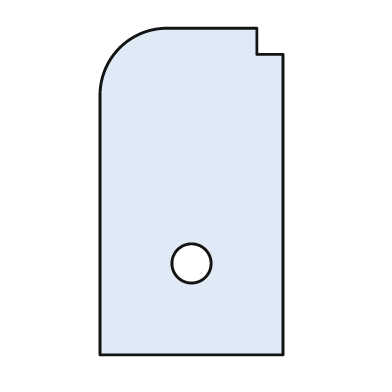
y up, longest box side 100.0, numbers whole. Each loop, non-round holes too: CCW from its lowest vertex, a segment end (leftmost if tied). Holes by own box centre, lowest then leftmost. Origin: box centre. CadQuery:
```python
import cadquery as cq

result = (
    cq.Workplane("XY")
    .moveTo(-28.0, -50.0)
    .lineTo(28.0, -50.0)
    .lineTo(28.0, 42.0)
    .lineTo(20.0, 42.0)
    .lineTo(20.0, 50.0)
    .lineTo(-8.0, 50.0)
    .threePointArc((-22.0, 44.0), (-28.0, 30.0))
    .close()
    .moveTo(0.0, -22.0)
    .circle(6.0)
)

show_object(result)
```